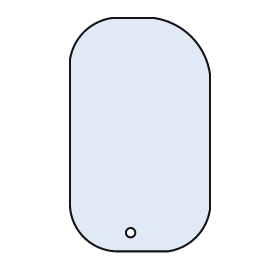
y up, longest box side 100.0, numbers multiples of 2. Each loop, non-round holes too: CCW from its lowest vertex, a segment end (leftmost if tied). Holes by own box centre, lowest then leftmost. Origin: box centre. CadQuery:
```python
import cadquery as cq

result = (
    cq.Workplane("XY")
    .moveTo(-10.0, -50.0)
    .lineTo(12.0, -50.0)
    .threePointArc((24.0, -44.0), (30.0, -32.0))
    .lineTo(30.0, 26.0)
    .threePointArc((22.0, 42.0), (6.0, 50.0))
    .lineTo(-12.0, 50.0)
    .threePointArc((-24.0, 44.0), (-30.0, 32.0))
    .lineTo(-30.0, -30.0)
    .threePointArc((-24.0, -44.0), (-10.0, -50.0))
    .close()
    .moveTo(-4.0, -42.0)
    .circle(2.0)
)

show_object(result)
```